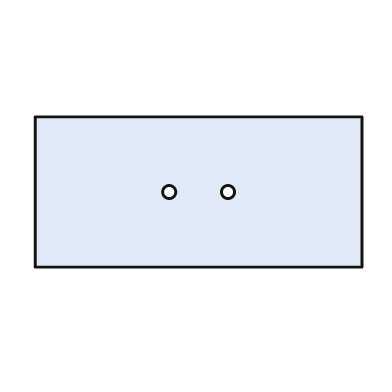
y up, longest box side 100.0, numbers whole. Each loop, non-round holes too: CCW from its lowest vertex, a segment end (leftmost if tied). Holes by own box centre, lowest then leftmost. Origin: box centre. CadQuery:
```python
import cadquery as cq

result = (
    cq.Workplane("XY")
    .moveTo(-50.0, -23.0)
    .lineTo(50.0, -23.0)
    .lineTo(50.0, 23.0)
    .lineTo(-50.0, 23.0)
    .close()
    .moveTo(-9.0, 0.0)
    .circle(2.0)
    .moveTo(9.0, 0.0)
    .circle(2.0)
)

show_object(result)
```